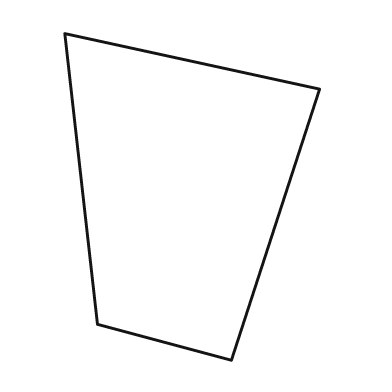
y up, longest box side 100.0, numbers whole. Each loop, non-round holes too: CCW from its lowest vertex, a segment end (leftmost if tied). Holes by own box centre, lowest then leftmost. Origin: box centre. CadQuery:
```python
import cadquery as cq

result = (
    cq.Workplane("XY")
    .moveTo(12.0, -50.0)
    .lineTo(39.0, 33.0)
    .lineTo(-39.0, 50.0)
    .lineTo(-29.0, -39.0)
    .close()
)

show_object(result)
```